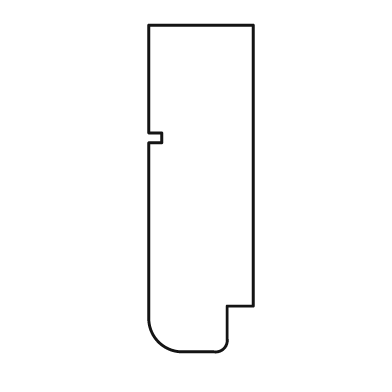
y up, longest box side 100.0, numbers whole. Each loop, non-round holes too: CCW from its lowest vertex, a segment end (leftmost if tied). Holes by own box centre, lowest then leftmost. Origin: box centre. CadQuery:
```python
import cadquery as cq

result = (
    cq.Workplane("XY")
    .moveTo(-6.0, -50.0)
    .lineTo(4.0, -50.0)
    .threePointArc((7.0, -49.0), (8.0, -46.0))
    .lineTo(8.0, -36.0)
    .lineTo(16.0, -36.0)
    .lineTo(16.0, 50.0)
    .lineTo(-16.0, 50.0)
    .lineTo(-16.0, 17.0)
    .lineTo(-12.0, 17.0)
    .lineTo(-12.0, 14.0)
    .lineTo(-16.0, 14.0)
    .lineTo(-16.0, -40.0)
    .threePointArc((-13.0, -47.0), (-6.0, -50.0))
    .close()
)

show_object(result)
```